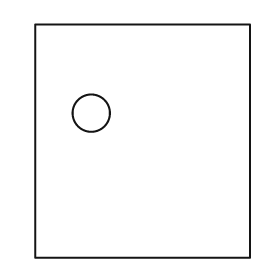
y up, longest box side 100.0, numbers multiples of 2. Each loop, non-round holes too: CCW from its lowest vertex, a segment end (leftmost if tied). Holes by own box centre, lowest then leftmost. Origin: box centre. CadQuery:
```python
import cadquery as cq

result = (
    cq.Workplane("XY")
    .moveTo(-46.0, -50.0)
    .lineTo(46.0, -50.0)
    .lineTo(46.0, 50.0)
    .lineTo(-46.0, 50.0)
    .close()
    .moveTo(-22.0, 12.0)
    .circle(8.0)
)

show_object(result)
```